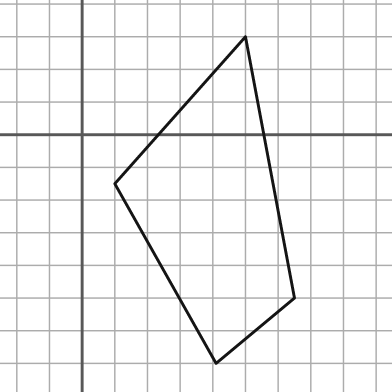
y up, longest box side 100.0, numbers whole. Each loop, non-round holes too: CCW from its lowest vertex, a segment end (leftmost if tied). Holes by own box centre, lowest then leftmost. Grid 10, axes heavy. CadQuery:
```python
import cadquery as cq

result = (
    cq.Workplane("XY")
    .moveTo(41.0, -70.0)
    .lineTo(65.0, -50.0)
    .lineTo(50.0, 30.0)
    .lineTo(10.0, -15.0)
    .close()
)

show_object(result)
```